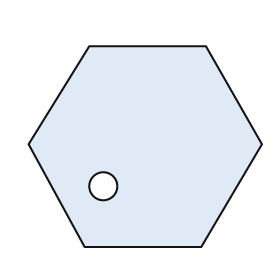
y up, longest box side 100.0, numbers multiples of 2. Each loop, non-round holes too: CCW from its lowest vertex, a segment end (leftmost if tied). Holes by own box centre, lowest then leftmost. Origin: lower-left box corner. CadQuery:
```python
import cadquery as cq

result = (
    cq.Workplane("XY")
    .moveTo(24.0, 0.0)
    .lineTo(74.0, 0.0)
    .lineTo(100.0, 44.0)
    .lineTo(76.0, 86.0)
    .lineTo(26.0, 86.0)
    .lineTo(0.0, 44.0)
    .close()
    .moveTo(32.0, 26.0)
    .circle(6.0)
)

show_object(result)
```